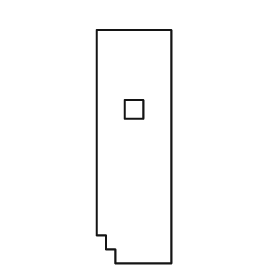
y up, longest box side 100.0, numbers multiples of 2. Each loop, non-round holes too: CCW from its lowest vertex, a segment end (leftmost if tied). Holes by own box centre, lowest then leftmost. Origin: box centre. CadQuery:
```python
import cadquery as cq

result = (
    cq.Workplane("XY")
    .moveTo(-8.0, -50.0)
    .lineTo(16.0, -50.0)
    .lineTo(16.0, 50.0)
    .lineTo(-16.0, 50.0)
    .lineTo(-16.0, -38.0)
    .lineTo(-12.0, -38.0)
    .lineTo(-12.0, -44.0)
    .lineTo(-8.0, -44.0)
    .close()
    .moveTo(-4.0, 12.0)
    .lineTo(4.0, 12.0)
    .lineTo(4.0, 20.0)
    .lineTo(-4.0, 20.0)
    .close()
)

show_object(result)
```